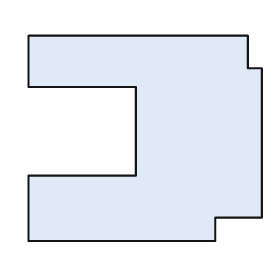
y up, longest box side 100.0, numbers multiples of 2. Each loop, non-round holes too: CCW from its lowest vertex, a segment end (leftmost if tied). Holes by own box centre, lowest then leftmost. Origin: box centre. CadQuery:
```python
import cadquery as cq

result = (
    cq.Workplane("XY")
    .moveTo(-50.0, -44.0)
    .lineTo(30.0, -44.0)
    .lineTo(30.0, -34.0)
    .lineTo(50.0, -34.0)
    .lineTo(50.0, 30.0)
    .lineTo(44.0, 30.0)
    .lineTo(44.0, 44.0)
    .lineTo(-50.0, 44.0)
    .lineTo(-50.0, 22.0)
    .lineTo(-4.0, 22.0)
    .lineTo(-4.0, -16.0)
    .lineTo(-50.0, -16.0)
    .close()
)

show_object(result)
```